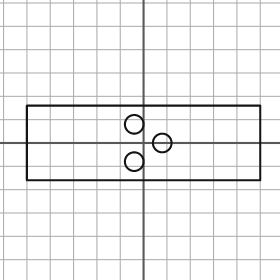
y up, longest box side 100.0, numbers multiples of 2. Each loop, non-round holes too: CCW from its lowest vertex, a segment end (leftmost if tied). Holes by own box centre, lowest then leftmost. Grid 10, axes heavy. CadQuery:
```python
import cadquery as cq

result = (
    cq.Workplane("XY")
    .moveTo(-50.0, -16.0)
    .lineTo(50.0, -16.0)
    .lineTo(50.0, 16.0)
    .lineTo(-50.0, 16.0)
    .close()
    .moveTo(-4.0, -8.0)
    .circle(4.0)
    .moveTo(8.0, 0.0)
    .circle(4.0)
    .moveTo(-4.0, 8.0)
    .circle(4.0)
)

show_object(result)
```